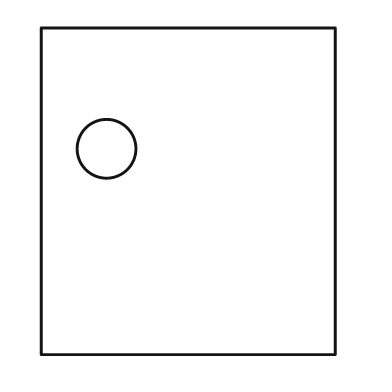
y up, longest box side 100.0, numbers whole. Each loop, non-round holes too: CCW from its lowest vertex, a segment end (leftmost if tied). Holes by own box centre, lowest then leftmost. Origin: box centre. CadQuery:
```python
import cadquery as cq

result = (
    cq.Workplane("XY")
    .moveTo(-45.0, -50.0)
    .lineTo(45.0, -50.0)
    .lineTo(45.0, 50.0)
    .lineTo(-45.0, 50.0)
    .close()
    .moveTo(-25.0, 13.0)
    .circle(9.0)
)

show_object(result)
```